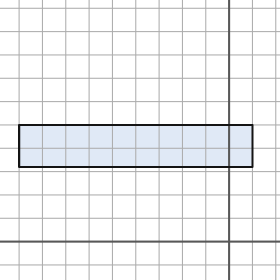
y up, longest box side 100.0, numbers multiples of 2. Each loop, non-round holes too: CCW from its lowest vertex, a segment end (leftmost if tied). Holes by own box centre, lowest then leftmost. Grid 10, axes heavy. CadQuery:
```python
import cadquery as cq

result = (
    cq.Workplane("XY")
    .moveTo(-90.0, 32.0)
    .lineTo(10.0, 32.0)
    .lineTo(10.0, 50.0)
    .lineTo(-90.0, 50.0)
    .close()
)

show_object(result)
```